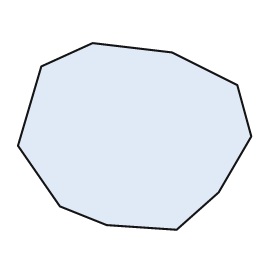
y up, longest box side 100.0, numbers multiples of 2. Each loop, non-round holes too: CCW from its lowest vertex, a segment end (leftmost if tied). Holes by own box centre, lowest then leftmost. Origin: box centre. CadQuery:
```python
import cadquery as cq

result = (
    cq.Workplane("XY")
    .moveTo(18.0, -40.0)
    .lineTo(36.0, -24.0)
    .lineTo(50.0, 0.0)
    .lineTo(44.0, 22.0)
    .lineTo(16.0, 36.0)
    .lineTo(-18.0, 40.0)
    .lineTo(-40.0, 30.0)
    .lineTo(-50.0, -4.0)
    .lineTo(-32.0, -30.0)
    .lineTo(-12.0, -38.0)
    .close()
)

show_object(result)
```